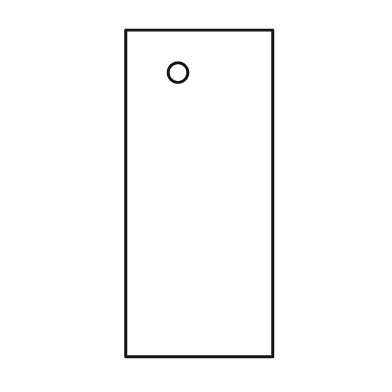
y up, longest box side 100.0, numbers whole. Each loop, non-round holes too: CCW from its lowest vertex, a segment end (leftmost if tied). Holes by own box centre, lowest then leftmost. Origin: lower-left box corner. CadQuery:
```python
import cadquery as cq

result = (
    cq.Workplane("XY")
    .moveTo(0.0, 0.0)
    .lineTo(45.0, 0.0)
    .lineTo(45.0, 100.0)
    .lineTo(0.0, 100.0)
    .close()
    .moveTo(16.0, 87.0)
    .circle(3.0)
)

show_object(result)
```